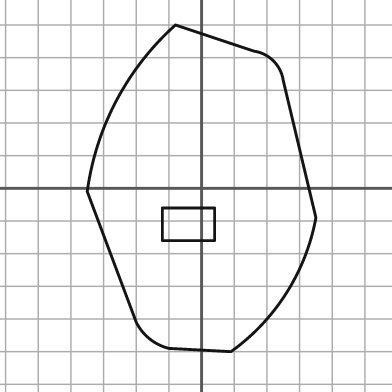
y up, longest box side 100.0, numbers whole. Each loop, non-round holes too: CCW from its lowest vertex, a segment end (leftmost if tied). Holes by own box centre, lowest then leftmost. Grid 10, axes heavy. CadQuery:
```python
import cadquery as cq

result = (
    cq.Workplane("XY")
    .moveTo(9.0, -50.0)
    .threePointArc((26.0, -32.0), (35.0, -9.0))
    .lineTo(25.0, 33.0)
    .threePointArc((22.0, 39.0), (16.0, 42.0))
    .lineTo(-8.0, 50.0)
    .threePointArc((-26.0, 27.0), (-35.0, -1.0))
    .lineTo(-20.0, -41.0)
    .threePointArc((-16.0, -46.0), (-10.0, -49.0))
    .close()
    .moveTo(-12.0, -16.0)
    .lineTo(4.0, -16.0)
    .lineTo(4.0, -6.0)
    .lineTo(-12.0, -6.0)
    .close()
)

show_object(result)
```